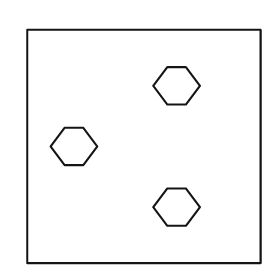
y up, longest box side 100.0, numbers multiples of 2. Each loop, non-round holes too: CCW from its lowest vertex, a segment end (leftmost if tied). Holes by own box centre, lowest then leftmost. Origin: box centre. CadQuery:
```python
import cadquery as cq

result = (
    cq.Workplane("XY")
    .moveTo(-50.0, -50.0)
    .lineTo(50.0, -50.0)
    .lineTo(50.0, 50.0)
    .lineTo(-50.0, 50.0)
    .close()
    .moveTo(10.0, -34.0)
    .lineTo(18.0, -34.0)
    .lineTo(24.0, -26.0)
    .lineTo(18.0, -18.0)
    .lineTo(10.0, -18.0)
    .lineTo(4.0, -26.0)
    .close()
    .moveTo(-34.0, -8.0)
    .lineTo(-26.0, -8.0)
    .lineTo(-20.0, 0.0)
    .lineTo(-26.0, 8.0)
    .lineTo(-34.0, 8.0)
    .lineTo(-40.0, 0.0)
    .close()
    .moveTo(10.0, 18.0)
    .lineTo(18.0, 18.0)
    .lineTo(24.0, 26.0)
    .lineTo(18.0, 34.0)
    .lineTo(10.0, 34.0)
    .lineTo(4.0, 26.0)
    .close()
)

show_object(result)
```